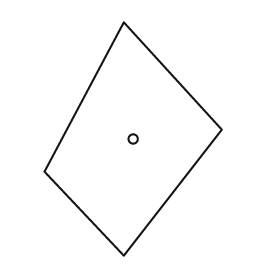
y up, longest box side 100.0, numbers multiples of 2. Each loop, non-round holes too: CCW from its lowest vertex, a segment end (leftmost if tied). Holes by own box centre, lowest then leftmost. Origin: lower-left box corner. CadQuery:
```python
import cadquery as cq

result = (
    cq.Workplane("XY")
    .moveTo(34.0, 0.0)
    .lineTo(76.0, 54.0)
    .lineTo(34.0, 100.0)
    .lineTo(0.0, 36.0)
    .close()
    .moveTo(38.0, 50.0)
    .circle(2.0)
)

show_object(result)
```